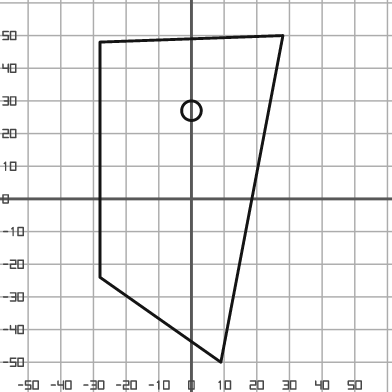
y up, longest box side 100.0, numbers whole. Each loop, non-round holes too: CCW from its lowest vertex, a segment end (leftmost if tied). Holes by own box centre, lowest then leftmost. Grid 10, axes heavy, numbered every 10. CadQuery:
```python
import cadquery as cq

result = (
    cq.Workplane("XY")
    .moveTo(9.0, -50.0)
    .lineTo(28.0, 50.0)
    .lineTo(-28.0, 48.0)
    .lineTo(-28.0, -24.0)
    .close()
    .moveTo(0.0, 27.0)
    .circle(3.0)
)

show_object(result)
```